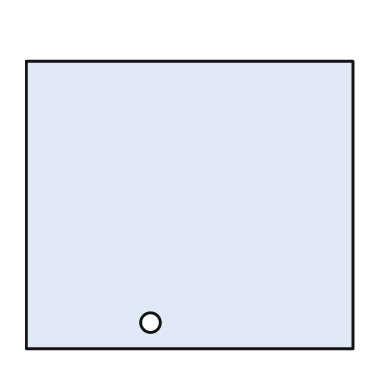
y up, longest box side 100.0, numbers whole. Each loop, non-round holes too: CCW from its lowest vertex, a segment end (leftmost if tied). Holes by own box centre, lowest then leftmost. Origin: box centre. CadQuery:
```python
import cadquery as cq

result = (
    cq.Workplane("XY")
    .moveTo(-50.0, -44.0)
    .lineTo(50.0, -44.0)
    .lineTo(50.0, 44.0)
    .lineTo(-50.0, 44.0)
    .close()
    .moveTo(-12.0, -36.0)
    .circle(3.0)
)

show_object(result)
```